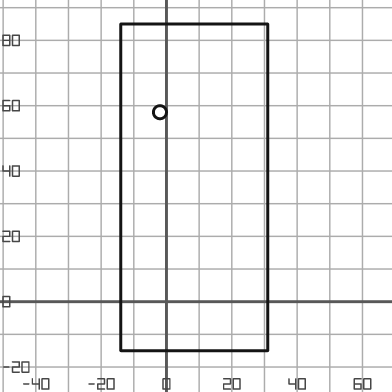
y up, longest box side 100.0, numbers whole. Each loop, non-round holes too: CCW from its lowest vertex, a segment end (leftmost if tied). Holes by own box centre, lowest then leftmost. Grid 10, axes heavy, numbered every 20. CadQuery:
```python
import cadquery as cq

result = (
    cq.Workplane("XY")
    .moveTo(-14.0, -15.0)
    .lineTo(31.0, -15.0)
    .lineTo(31.0, 85.0)
    .lineTo(-14.0, 85.0)
    .close()
    .moveTo(-2.0, 58.0)
    .circle(2.0)
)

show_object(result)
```